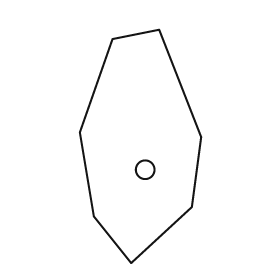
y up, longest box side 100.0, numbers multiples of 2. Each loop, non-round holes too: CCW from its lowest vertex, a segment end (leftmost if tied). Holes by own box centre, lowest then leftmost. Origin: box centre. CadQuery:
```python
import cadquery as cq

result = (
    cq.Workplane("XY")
    .moveTo(-4.0, -50.0)
    .lineTo(22.0, -26.0)
    .lineTo(26.0, 4.0)
    .lineTo(8.0, 50.0)
    .lineTo(-12.0, 46.0)
    .lineTo(-26.0, 6.0)
    .lineTo(-20.0, -30.0)
    .close()
    .moveTo(2.0, -10.0)
    .circle(4.0)
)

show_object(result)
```